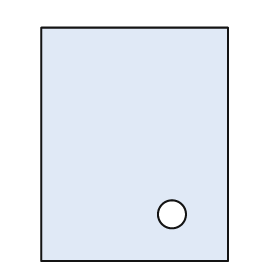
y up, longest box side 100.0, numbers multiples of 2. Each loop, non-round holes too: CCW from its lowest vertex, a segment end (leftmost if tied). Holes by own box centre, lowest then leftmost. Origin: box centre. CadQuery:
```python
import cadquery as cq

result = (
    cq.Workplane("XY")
    .moveTo(-40.0, -50.0)
    .lineTo(40.0, -50.0)
    .lineTo(40.0, 50.0)
    .lineTo(-40.0, 50.0)
    .close()
    .moveTo(16.0, -30.0)
    .circle(6.0)
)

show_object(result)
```